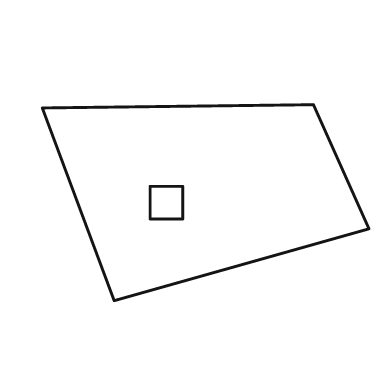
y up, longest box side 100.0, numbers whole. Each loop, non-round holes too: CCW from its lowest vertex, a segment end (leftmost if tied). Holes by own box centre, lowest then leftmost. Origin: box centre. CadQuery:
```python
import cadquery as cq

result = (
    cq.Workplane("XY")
    .moveTo(-28.0, -30.0)
    .lineTo(50.0, -8.0)
    .lineTo(33.0, 30.0)
    .lineTo(-50.0, 29.0)
    .close()
    .moveTo(-17.0, -5.0)
    .lineTo(-7.0, -5.0)
    .lineTo(-7.0, 5.0)
    .lineTo(-17.0, 5.0)
    .close()
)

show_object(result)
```